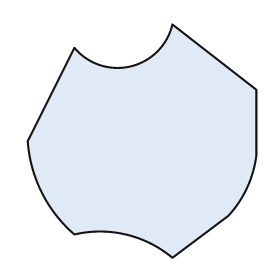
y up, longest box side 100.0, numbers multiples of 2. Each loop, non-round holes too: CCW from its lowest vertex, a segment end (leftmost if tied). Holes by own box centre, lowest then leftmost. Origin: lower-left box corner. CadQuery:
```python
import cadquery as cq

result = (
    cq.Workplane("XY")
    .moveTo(62.0, 0.0)
    .lineTo(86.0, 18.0)
    .threePointArc((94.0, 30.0), (98.0, 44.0))
    .lineTo(98.0, 72.0)
    .lineTo(62.0, 100.0)
    .threePointArc((44.0, 82.0), (20.0, 90.0))
    .lineTo(0.0, 50.0)
    .threePointArc((6.0, 28.0), (20.0, 10.0))
    .threePointArc((42.0, 10.0), (62.0, 0.0))
    .close()
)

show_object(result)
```